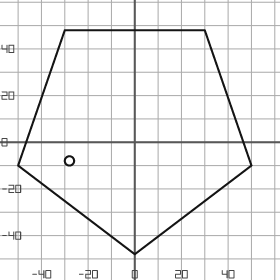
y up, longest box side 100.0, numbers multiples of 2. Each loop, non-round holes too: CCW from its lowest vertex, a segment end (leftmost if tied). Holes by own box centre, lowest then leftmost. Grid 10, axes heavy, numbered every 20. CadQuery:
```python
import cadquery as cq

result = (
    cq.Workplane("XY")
    .moveTo(0.0, -48.0)
    .lineTo(50.0, -10.0)
    .lineTo(30.0, 48.0)
    .lineTo(-30.0, 48.0)
    .lineTo(-50.0, -10.0)
    .close()
    .moveTo(-28.0, -8.0)
    .circle(2.0)
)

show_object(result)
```